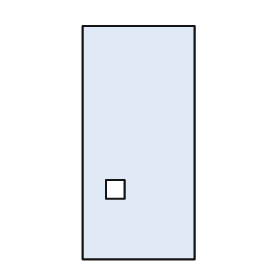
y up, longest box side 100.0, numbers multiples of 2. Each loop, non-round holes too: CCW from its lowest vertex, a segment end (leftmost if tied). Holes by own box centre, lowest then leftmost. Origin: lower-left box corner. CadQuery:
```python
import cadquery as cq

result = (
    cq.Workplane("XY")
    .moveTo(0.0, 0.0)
    .lineTo(48.0, 0.0)
    .lineTo(48.0, 100.0)
    .lineTo(0.0, 100.0)
    .close()
    .moveTo(10.0, 26.0)
    .lineTo(18.0, 26.0)
    .lineTo(18.0, 34.0)
    .lineTo(10.0, 34.0)
    .close()
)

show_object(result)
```